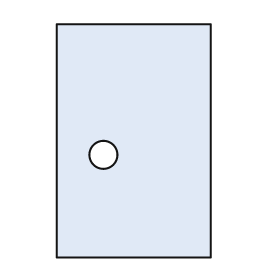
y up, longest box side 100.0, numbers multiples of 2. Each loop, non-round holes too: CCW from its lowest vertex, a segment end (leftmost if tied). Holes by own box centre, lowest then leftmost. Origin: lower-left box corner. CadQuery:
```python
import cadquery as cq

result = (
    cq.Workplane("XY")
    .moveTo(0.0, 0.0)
    .lineTo(66.0, 0.0)
    .lineTo(66.0, 100.0)
    .lineTo(0.0, 100.0)
    .close()
    .moveTo(20.0, 44.0)
    .circle(6.0)
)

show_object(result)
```